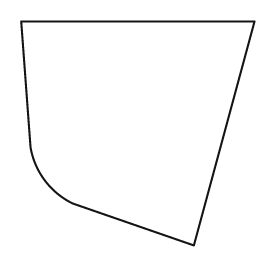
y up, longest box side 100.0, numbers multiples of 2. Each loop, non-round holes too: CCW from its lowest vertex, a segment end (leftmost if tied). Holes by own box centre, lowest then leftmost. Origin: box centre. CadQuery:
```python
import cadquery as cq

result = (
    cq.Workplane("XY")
    .moveTo(24.0, -48.0)
    .lineTo(50.0, 48.0)
    .lineTo(-50.0, 48.0)
    .lineTo(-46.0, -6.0)
    .threePointArc((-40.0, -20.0), (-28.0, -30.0))
    .close()
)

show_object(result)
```